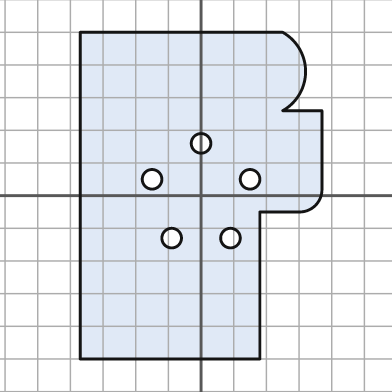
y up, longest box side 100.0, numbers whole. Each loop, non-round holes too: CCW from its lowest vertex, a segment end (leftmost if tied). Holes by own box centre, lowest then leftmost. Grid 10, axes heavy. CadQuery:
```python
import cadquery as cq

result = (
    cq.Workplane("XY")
    .moveTo(-37.0, -50.0)
    .lineTo(18.0, -50.0)
    .lineTo(18.0, -5.0)
    .lineTo(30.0, -5.0)
    .threePointArc((35.0, -3.0), (37.0, 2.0))
    .lineTo(37.0, 26.0)
    .lineTo(25.0, 26.0)
    .threePointArc((32.0, 38.0), (25.0, 50.0))
    .lineTo(-37.0, 50.0)
    .close()
    .moveTo(-9.0, -13.0)
    .circle(3.0)
    .moveTo(9.0, -13.0)
    .circle(3.0)
    .moveTo(-15.0, 5.0)
    .circle(3.0)
    .moveTo(15.0, 5.0)
    .circle(3.0)
    .moveTo(0.0, 16.0)
    .circle(3.0)
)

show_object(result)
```